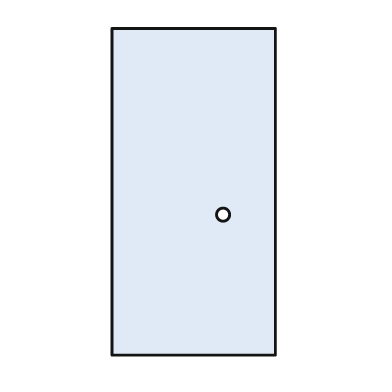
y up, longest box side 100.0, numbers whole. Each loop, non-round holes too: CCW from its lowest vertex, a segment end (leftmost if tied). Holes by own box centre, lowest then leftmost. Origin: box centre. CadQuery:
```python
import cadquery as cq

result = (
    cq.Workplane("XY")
    .moveTo(-25.0, -50.0)
    .lineTo(25.0, -50.0)
    .lineTo(25.0, 50.0)
    .lineTo(-25.0, 50.0)
    .close()
    .moveTo(9.0, -7.0)
    .circle(2.0)
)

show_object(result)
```